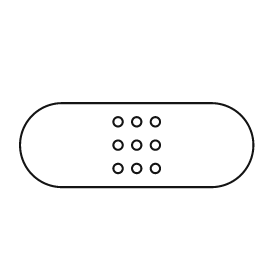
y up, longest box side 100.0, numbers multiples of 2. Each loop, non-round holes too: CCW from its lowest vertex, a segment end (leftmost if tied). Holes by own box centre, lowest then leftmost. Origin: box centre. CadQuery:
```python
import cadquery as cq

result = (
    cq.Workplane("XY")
    .moveTo(-32.0, -18.0)
    .lineTo(32.0, -18.0)
    .threePointArc((50.0, 0.0), (32.0, 18.0))
    .lineTo(-32.0, 18.0)
    .threePointArc((-50.0, 0.0), (-32.0, -18.0))
    .close()
    .moveTo(-8.0, -10.0)
    .circle(2.0)
    .moveTo(0.0, -10.0)
    .circle(2.0)
    .moveTo(8.0, -10.0)
    .circle(2.0)
    .moveTo(-8.0, 0.0)
    .circle(2.0)
    .moveTo(0.0, 0.0)
    .circle(2.0)
    .moveTo(8.0, 0.0)
    .circle(2.0)
    .moveTo(-8.0, 10.0)
    .circle(2.0)
    .moveTo(0.0, 10.0)
    .circle(2.0)
    .moveTo(8.0, 10.0)
    .circle(2.0)
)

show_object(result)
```